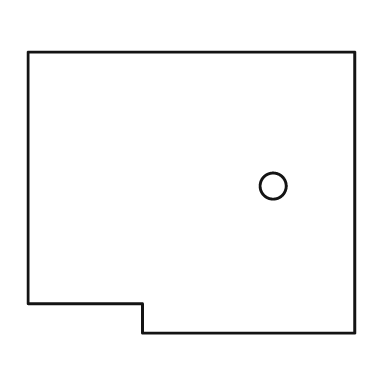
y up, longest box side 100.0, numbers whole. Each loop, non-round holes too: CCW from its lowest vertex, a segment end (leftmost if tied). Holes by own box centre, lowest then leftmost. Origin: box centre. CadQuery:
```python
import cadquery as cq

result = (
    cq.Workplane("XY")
    .moveTo(-15.0, -43.0)
    .lineTo(50.0, -43.0)
    .lineTo(50.0, 43.0)
    .lineTo(-50.0, 43.0)
    .lineTo(-50.0, -34.0)
    .lineTo(-15.0, -34.0)
    .close()
    .moveTo(25.0, 2.0)
    .circle(4.0)
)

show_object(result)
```